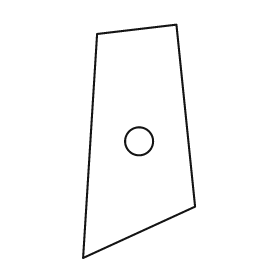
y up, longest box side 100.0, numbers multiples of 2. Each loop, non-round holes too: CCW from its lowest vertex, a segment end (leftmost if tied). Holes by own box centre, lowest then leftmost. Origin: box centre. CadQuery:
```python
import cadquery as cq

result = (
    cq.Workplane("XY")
    .moveTo(-24.0, -50.0)
    .lineTo(24.0, -28.0)
    .lineTo(16.0, 50.0)
    .lineTo(-18.0, 46.0)
    .close()
    .moveTo(0.0, 0.0)
    .circle(6.0)
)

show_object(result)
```